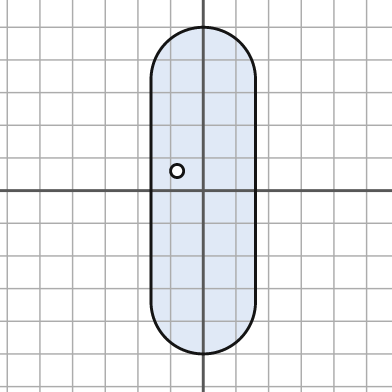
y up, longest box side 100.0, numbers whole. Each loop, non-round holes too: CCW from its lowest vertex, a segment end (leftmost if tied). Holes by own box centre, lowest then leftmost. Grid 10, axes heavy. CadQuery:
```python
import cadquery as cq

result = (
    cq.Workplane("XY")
    .moveTo(-16.0, -34.0)
    .threePointArc((0.0, -50.0), (16.0, -34.0))
    .lineTo(16.0, 34.0)
    .threePointArc((0.0, 50.0), (-16.0, 34.0))
    .close()
    .moveTo(-8.0, 6.0)
    .circle(2.0)
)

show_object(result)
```